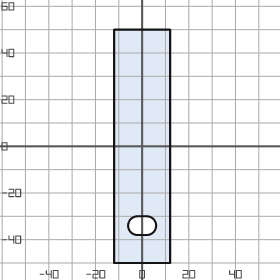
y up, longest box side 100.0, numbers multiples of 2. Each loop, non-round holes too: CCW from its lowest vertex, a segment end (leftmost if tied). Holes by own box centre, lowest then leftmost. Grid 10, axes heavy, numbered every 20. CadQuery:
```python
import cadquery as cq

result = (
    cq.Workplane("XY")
    .moveTo(-12.0, -50.0)
    .lineTo(12.0, -50.0)
    .lineTo(12.0, 50.0)
    .lineTo(-12.0, 50.0)
    .close()
    .moveTo(-2.0, -38.0)
    .lineTo(2.0, -38.0)
    .threePointArc((6.0, -34.0), (2.0, -30.0))
    .lineTo(-2.0, -30.0)
    .threePointArc((-6.0, -34.0), (-2.0, -38.0))
    .close()
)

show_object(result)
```